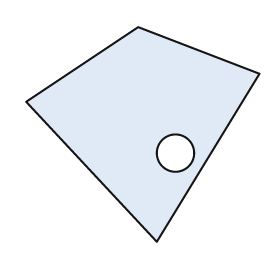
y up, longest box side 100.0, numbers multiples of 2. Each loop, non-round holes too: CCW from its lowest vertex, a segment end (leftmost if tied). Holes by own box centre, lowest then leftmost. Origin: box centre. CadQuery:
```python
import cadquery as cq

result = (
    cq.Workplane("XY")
    .moveTo(6.0, -46.0)
    .lineTo(50.0, 26.0)
    .lineTo(-2.0, 46.0)
    .lineTo(-50.0, 14.0)
    .close()
    .moveTo(14.0, -8.0)
    .circle(8.0)
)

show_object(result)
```